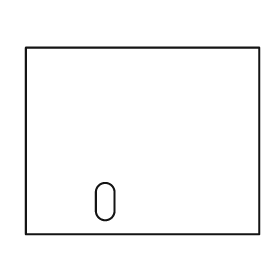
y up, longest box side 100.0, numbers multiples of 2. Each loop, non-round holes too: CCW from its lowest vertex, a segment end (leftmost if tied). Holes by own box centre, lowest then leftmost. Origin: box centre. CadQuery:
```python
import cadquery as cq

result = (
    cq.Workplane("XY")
    .moveTo(-50.0, -40.0)
    .lineTo(50.0, -40.0)
    .lineTo(50.0, 40.0)
    .lineTo(-50.0, 40.0)
    .close()
    .moveTo(-20.0, -30.0)
    .threePointArc((-16.0, -34.0), (-12.0, -30.0))
    .lineTo(-12.0, -22.0)
    .threePointArc((-16.0, -18.0), (-20.0, -22.0))
    .close()
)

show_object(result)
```